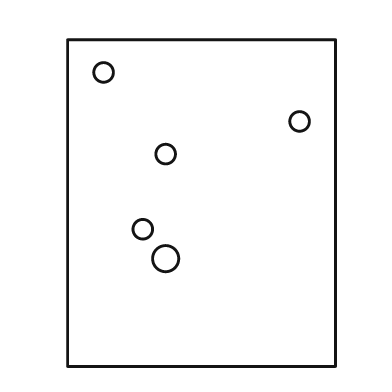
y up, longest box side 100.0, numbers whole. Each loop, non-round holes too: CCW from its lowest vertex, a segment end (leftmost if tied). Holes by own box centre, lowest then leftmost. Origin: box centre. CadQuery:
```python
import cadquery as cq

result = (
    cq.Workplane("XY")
    .moveTo(-41.0, -50.0)
    .lineTo(41.0, -50.0)
    .lineTo(41.0, 50.0)
    .lineTo(-41.0, 50.0)
    .close()
    .moveTo(-11.0, -17.0)
    .circle(4.0)
    .moveTo(-18.0, -8.0)
    .circle(3.0)
    .moveTo(-11.0, 15.0)
    .circle(3.0)
    .moveTo(30.0, 25.0)
    .circle(3.0)
    .moveTo(-30.0, 40.0)
    .circle(3.0)
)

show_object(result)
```